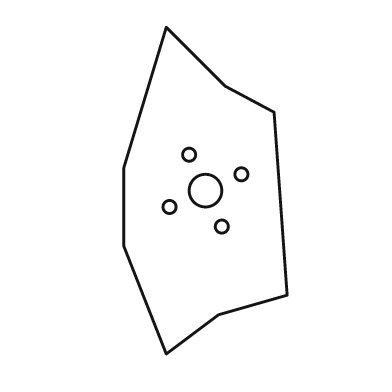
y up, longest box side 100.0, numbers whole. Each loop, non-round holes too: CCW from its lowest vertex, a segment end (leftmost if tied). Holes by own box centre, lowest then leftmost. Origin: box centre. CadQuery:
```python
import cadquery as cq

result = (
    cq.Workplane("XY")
    .moveTo(-12.0, -50.0)
    .lineTo(4.0, -38.0)
    .lineTo(25.0, -32.0)
    .lineTo(21.0, 24.0)
    .lineTo(6.0, 32.0)
    .lineTo(-12.0, 50.0)
    .lineTo(-25.0, 7.0)
    .lineTo(-25.0, -17.0)
    .close()
    .moveTo(5.0, -11.0)
    .circle(2.0)
    .moveTo(-11.0, -5.0)
    .circle(2.0)
    .moveTo(0.0, 0.0)
    .circle(5.0)
    .moveTo(11.0, 5.0)
    .circle(2.0)
    .moveTo(-5.0, 11.0)
    .circle(2.0)
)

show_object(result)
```